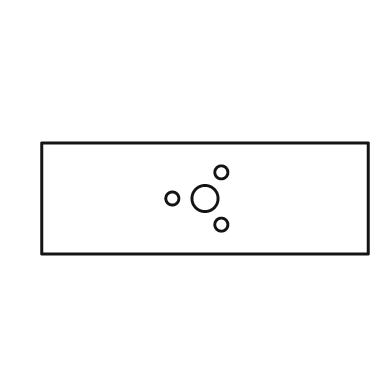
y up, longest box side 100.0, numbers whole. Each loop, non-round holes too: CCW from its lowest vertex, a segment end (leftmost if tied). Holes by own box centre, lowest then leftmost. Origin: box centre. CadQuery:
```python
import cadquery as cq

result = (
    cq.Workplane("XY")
    .moveTo(-50.0, -17.0)
    .lineTo(50.0, -17.0)
    .lineTo(50.0, 17.0)
    .lineTo(-50.0, 17.0)
    .close()
    .moveTo(5.0, -8.0)
    .circle(2.0)
    .moveTo(-10.0, 0.0)
    .circle(2.0)
    .moveTo(0.0, 0.0)
    .circle(4.0)
    .moveTo(5.0, 8.0)
    .circle(2.0)
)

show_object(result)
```